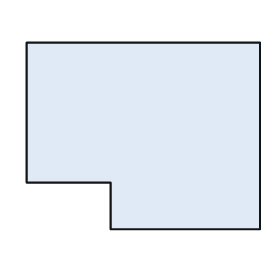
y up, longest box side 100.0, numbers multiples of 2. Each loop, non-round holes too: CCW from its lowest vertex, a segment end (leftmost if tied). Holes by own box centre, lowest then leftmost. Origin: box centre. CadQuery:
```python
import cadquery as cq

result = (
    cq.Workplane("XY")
    .moveTo(-14.0, -40.0)
    .lineTo(50.0, -40.0)
    .lineTo(50.0, 40.0)
    .lineTo(-50.0, 40.0)
    .lineTo(-50.0, -20.0)
    .lineTo(-14.0, -20.0)
    .close()
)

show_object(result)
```